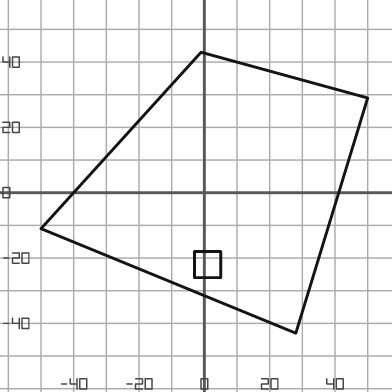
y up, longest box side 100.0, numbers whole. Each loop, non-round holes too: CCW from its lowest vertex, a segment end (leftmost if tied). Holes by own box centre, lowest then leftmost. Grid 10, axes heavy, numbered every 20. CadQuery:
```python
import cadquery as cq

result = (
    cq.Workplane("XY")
    .moveTo(28.0, -43.0)
    .lineTo(50.0, 29.0)
    .lineTo(-1.0, 43.0)
    .lineTo(-50.0, -11.0)
    .close()
    .moveTo(-3.0, -26.0)
    .lineTo(5.0, -26.0)
    .lineTo(5.0, -18.0)
    .lineTo(-3.0, -18.0)
    .close()
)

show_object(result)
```